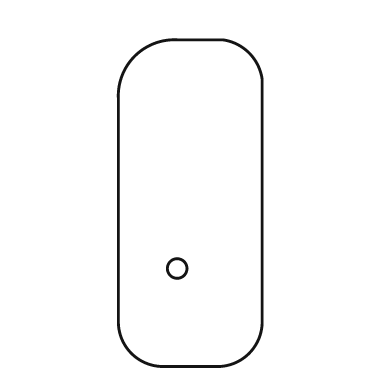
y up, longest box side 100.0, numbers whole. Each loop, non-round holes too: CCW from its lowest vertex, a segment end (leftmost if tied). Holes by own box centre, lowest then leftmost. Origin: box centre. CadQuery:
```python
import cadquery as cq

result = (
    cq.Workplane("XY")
    .moveTo(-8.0, -50.0)
    .lineTo(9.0, -50.0)
    .threePointArc((18.0, -46.0), (22.0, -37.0))
    .lineTo(22.0, 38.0)
    .threePointArc((18.0, 46.0), (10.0, 50.0))
    .lineTo(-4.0, 50.0)
    .threePointArc((-17.0, 45.0), (-22.0, 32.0))
    .lineTo(-22.0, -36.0)
    .threePointArc((-18.0, -46.0), (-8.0, -50.0))
    .close()
    .moveTo(-4.0, -20.0)
    .circle(3.0)
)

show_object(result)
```